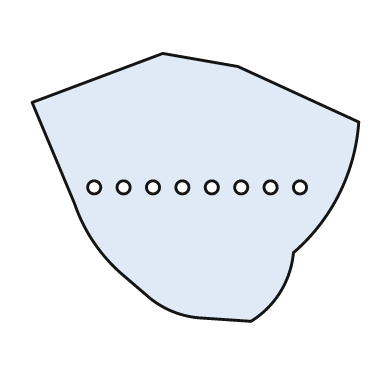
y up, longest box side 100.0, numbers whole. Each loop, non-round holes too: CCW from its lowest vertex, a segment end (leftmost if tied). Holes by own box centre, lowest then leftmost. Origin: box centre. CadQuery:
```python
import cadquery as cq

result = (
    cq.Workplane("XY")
    .moveTo(17.0, -41.0)
    .threePointArc((26.0, -32.0), (30.0, -20.0))
    .threePointArc((44.0, -2.0), (50.0, 20.0))
    .lineTo(13.0, 37.0)
    .lineTo(-10.0, 41.0)
    .lineTo(-50.0, 26.0)
    .lineTo(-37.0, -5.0)
    .threePointArc((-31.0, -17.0), (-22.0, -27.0))
    .lineTo(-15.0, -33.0)
    .threePointArc((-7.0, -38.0), (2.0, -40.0))
    .close()
    .moveTo(-31.0, 0.0)
    .circle(2.0)
    .moveTo(-22.0, 0.0)
    .circle(2.0)
    .moveTo(-13.0, 0.0)
    .circle(2.0)
    .moveTo(-4.0, 0.0)
    .circle(2.0)
    .moveTo(5.0, 0.0)
    .circle(2.0)
    .moveTo(14.0, 0.0)
    .circle(2.0)
    .moveTo(23.0, 0.0)
    .circle(2.0)
    .moveTo(32.0, 0.0)
    .circle(2.0)
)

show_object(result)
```